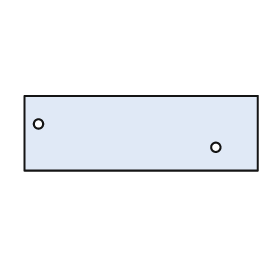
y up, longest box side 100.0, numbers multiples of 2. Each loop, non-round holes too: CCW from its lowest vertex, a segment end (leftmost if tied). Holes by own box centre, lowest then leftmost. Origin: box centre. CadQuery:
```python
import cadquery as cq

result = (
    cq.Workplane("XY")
    .moveTo(-50.0, -16.0)
    .lineTo(50.0, -16.0)
    .lineTo(50.0, 16.0)
    .lineTo(-50.0, 16.0)
    .close()
    .moveTo(32.0, -6.0)
    .circle(2.0)
    .moveTo(-44.0, 4.0)
    .circle(2.0)
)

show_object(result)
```